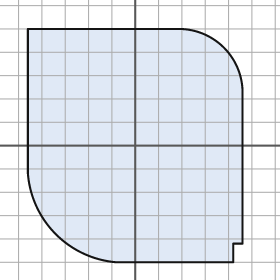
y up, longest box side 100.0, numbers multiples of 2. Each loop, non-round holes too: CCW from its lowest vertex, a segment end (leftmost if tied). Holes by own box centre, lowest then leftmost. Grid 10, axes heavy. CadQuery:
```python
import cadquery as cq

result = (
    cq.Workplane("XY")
    .moveTo(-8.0, -50.0)
    .lineTo(42.0, -50.0)
    .lineTo(42.0, -42.0)
    .lineTo(46.0, -42.0)
    .lineTo(46.0, 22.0)
    .threePointArc((38.0, 42.0), (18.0, 50.0))
    .lineTo(-46.0, 50.0)
    .lineTo(-46.0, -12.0)
    .threePointArc((-34.0, -38.0), (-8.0, -50.0))
    .close()
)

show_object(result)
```